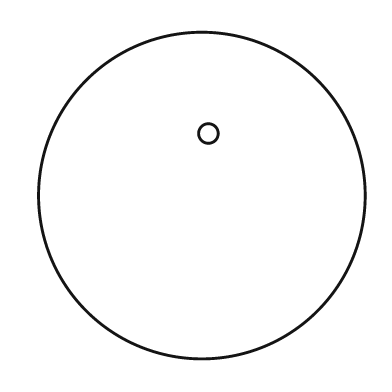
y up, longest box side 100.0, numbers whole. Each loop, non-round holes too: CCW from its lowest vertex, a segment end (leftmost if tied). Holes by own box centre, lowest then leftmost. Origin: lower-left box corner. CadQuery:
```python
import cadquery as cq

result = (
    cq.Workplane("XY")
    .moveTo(50.0, 50.0)
    .circle(50.0)
    .moveTo(52.0, 69.0)
    .circle(3.0)
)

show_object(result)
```